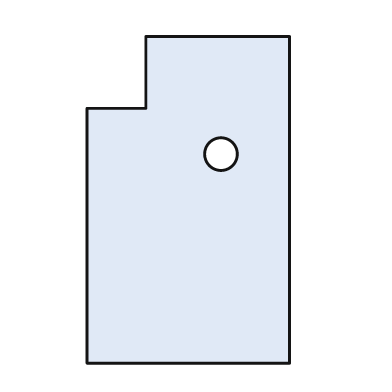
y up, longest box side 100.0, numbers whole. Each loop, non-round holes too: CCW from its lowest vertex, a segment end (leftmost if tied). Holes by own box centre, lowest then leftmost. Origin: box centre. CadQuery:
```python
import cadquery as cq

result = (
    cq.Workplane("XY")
    .moveTo(-31.0, -50.0)
    .lineTo(31.0, -50.0)
    .lineTo(31.0, 50.0)
    .lineTo(-13.0, 50.0)
    .lineTo(-13.0, 28.0)
    .lineTo(-31.0, 28.0)
    .close()
    .moveTo(10.0, 14.0)
    .circle(5.0)
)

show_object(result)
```